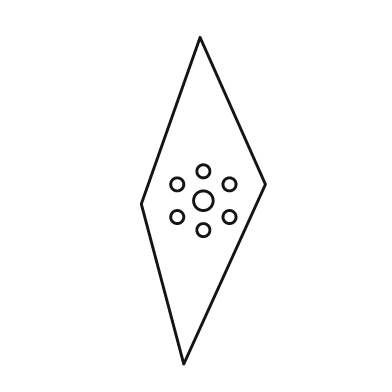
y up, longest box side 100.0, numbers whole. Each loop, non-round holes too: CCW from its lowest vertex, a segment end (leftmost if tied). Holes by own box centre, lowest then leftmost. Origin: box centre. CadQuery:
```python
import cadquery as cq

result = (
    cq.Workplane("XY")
    .moveTo(-6.0, -50.0)
    .lineTo(19.0, 5.0)
    .lineTo(-1.0, 50.0)
    .lineTo(-19.0, -1.0)
    .close()
    .moveTo(0.0, -9.0)
    .circle(2.0)
    .moveTo(-8.0, -5.0)
    .circle(2.0)
    .moveTo(8.0, -5.0)
    .circle(2.0)
    .moveTo(0.0, 0.0)
    .circle(3.0)
    .moveTo(-8.0, 5.0)
    .circle(2.0)
    .moveTo(8.0, 5.0)
    .circle(2.0)
    .moveTo(0.0, 9.0)
    .circle(2.0)
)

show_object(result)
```